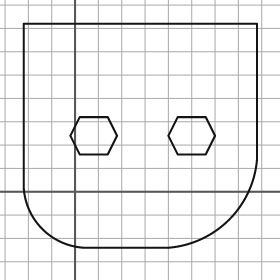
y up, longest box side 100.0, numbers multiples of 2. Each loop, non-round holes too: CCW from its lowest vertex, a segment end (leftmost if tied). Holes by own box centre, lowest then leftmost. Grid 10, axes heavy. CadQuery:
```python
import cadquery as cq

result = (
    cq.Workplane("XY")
    .moveTo(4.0, -24.0)
    .lineTo(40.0, -24.0)
    .threePointArc((66.0, -12.0), (78.0, 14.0))
    .lineTo(78.0, 72.0)
    .lineTo(-22.0, 72.0)
    .lineTo(-22.0, 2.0)
    .threePointArc((-14.0, -16.0), (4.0, -24.0))
    .close()
    .moveTo(2.0, 16.0)
    .lineTo(14.0, 16.0)
    .lineTo(18.0, 24.0)
    .lineTo(14.0, 32.0)
    .lineTo(2.0, 32.0)
    .lineTo(-2.0, 24.0)
    .close()
    .moveTo(44.0, 16.0)
    .lineTo(56.0, 16.0)
    .lineTo(60.0, 24.0)
    .lineTo(56.0, 32.0)
    .lineTo(44.0, 32.0)
    .lineTo(40.0, 24.0)
    .close()
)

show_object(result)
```